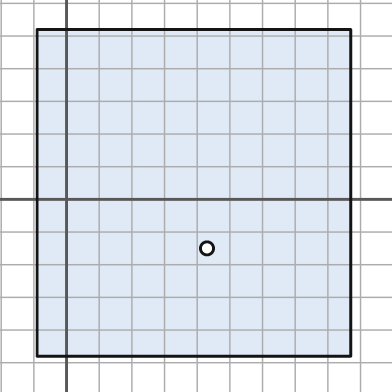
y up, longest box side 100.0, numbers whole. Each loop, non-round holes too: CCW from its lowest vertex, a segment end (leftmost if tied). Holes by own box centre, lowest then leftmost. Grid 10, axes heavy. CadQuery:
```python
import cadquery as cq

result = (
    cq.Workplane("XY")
    .moveTo(-9.0, -48.0)
    .lineTo(87.0, -48.0)
    .lineTo(87.0, 52.0)
    .lineTo(-9.0, 52.0)
    .close()
    .moveTo(43.0, -15.0)
    .circle(2.0)
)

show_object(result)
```